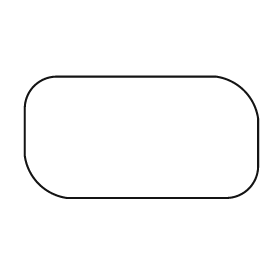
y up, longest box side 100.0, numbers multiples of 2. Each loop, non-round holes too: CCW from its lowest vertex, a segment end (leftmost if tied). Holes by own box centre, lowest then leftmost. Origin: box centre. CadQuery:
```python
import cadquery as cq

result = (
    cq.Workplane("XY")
    .moveTo(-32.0, -26.0)
    .lineTo(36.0, -26.0)
    .threePointArc((46.0, -22.0), (50.0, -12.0))
    .lineTo(50.0, 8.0)
    .threePointArc((44.0, 20.0), (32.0, 26.0))
    .lineTo(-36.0, 26.0)
    .threePointArc((-46.0, 22.0), (-50.0, 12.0))
    .lineTo(-50.0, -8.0)
    .threePointArc((-44.0, -20.0), (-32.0, -26.0))
    .close()
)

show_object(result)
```